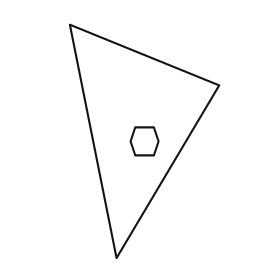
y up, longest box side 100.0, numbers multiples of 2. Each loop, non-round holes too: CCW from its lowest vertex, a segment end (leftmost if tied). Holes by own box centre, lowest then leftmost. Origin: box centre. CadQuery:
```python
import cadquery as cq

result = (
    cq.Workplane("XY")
    .moveTo(-12.0, -50.0)
    .lineTo(32.0, 24.0)
    .lineTo(-32.0, 50.0)
    .close()
    .moveTo(-4.0, -6.0)
    .lineTo(4.0, -6.0)
    .lineTo(6.0, 0.0)
    .lineTo(4.0, 6.0)
    .lineTo(-4.0, 6.0)
    .lineTo(-6.0, 0.0)
    .close()
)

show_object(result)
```